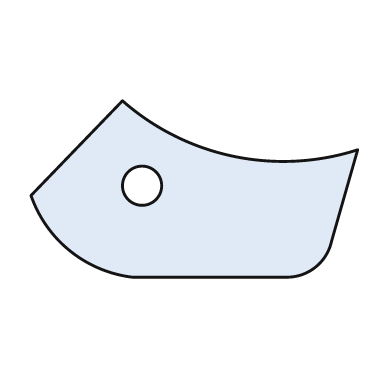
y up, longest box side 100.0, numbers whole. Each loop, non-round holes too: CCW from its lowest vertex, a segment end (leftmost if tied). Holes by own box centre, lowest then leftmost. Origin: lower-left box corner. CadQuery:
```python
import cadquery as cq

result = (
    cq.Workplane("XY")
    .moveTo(31.0, 0.0)
    .lineTo(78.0, 0.0)
    .threePointArc((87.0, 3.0), (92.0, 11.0))
    .lineTo(100.0, 39.0)
    .threePointArc((62.0, 37.0), (28.0, 54.0))
    .lineTo(0.0, 25.0)
    .threePointArc((12.0, 8.0), (31.0, 0.0))
    .close()
    .moveTo(34.0, 28.0)
    .circle(6.0)
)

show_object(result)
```